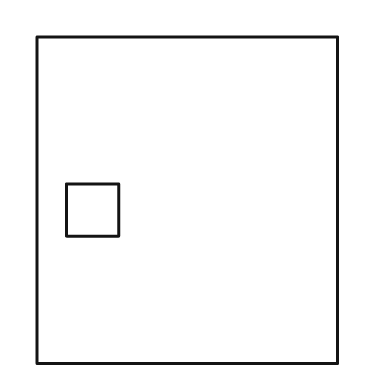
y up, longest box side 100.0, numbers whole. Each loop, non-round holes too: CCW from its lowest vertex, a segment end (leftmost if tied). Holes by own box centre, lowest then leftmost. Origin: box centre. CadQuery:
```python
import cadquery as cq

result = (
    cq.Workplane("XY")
    .moveTo(-46.0, -50.0)
    .lineTo(46.0, -50.0)
    .lineTo(46.0, 50.0)
    .lineTo(-46.0, 50.0)
    .close()
    .moveTo(-37.0, -11.0)
    .lineTo(-21.0, -11.0)
    .lineTo(-21.0, 5.0)
    .lineTo(-37.0, 5.0)
    .close()
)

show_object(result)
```